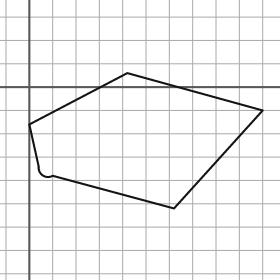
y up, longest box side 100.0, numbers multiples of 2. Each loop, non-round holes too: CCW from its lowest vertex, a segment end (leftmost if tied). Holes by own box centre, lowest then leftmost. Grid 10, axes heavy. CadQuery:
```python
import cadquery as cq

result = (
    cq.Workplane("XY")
    .moveTo(62.0, -52.0)
    .lineTo(100.0, -10.0)
    .lineTo(42.0, 6.0)
    .lineTo(0.0, -16.0)
    .lineTo(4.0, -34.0)
    .threePointArc((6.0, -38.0), (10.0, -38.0))
    .close()
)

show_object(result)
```